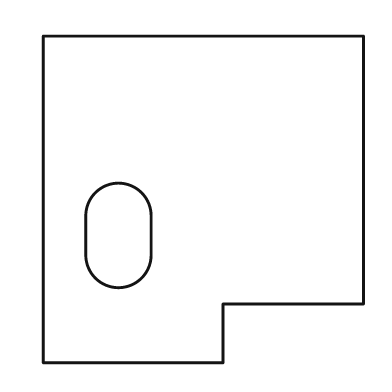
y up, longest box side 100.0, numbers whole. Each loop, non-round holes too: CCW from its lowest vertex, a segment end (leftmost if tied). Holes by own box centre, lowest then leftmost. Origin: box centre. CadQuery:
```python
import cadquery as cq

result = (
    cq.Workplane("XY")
    .moveTo(-49.0, -50.0)
    .lineTo(6.0, -50.0)
    .lineTo(6.0, -32.0)
    .lineTo(49.0, -32.0)
    .lineTo(49.0, 50.0)
    .lineTo(-49.0, 50.0)
    .close()
    .moveTo(-36.0, -17.0)
    .threePointArc((-26.0, -27.0), (-16.0, -17.0))
    .lineTo(-16.0, -5.0)
    .threePointArc((-26.0, 5.0), (-36.0, -5.0))
    .close()
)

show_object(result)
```